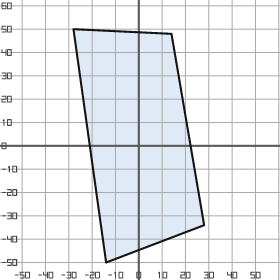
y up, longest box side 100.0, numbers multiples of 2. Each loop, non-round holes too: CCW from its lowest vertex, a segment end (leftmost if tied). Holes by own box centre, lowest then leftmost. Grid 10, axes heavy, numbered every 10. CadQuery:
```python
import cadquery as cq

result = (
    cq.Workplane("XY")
    .moveTo(-14.0, -50.0)
    .lineTo(28.0, -34.0)
    .lineTo(14.0, 48.0)
    .lineTo(-28.0, 50.0)
    .close()
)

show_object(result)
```